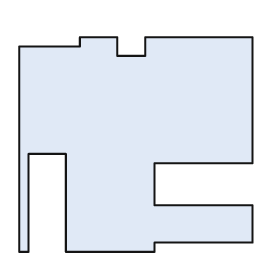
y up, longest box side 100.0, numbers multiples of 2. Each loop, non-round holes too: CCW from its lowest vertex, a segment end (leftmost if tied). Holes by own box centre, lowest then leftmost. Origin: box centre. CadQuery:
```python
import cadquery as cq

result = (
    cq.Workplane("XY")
    .moveTo(-50.0, -46.0)
    .lineTo(-46.0, -46.0)
    .lineTo(-46.0, -4.0)
    .lineTo(-30.0, -4.0)
    .lineTo(-30.0, -46.0)
    .lineTo(8.0, -46.0)
    .lineTo(8.0, -42.0)
    .lineTo(50.0, -42.0)
    .lineTo(50.0, -26.0)
    .lineTo(8.0, -26.0)
    .lineTo(8.0, -8.0)
    .lineTo(50.0, -8.0)
    .lineTo(50.0, 46.0)
    .lineTo(4.0, 46.0)
    .lineTo(4.0, 38.0)
    .lineTo(-8.0, 38.0)
    .lineTo(-8.0, 46.0)
    .lineTo(-24.0, 46.0)
    .lineTo(-24.0, 42.0)
    .lineTo(-50.0, 42.0)
    .close()
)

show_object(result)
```